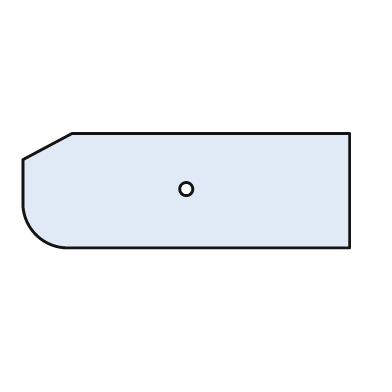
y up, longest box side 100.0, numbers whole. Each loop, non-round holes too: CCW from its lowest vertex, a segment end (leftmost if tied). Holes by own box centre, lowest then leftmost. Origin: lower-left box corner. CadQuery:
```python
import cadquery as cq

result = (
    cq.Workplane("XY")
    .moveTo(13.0, 0.0)
    .lineTo(100.0, 0.0)
    .lineTo(100.0, 35.0)
    .lineTo(15.0, 35.0)
    .lineTo(0.0, 27.0)
    .lineTo(0.0, 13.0)
    .threePointArc((4.0, 4.0), (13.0, 0.0))
    .close()
    .moveTo(50.0, 18.0)
    .circle(2.0)
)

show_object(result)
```